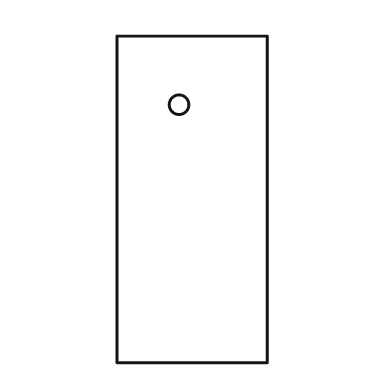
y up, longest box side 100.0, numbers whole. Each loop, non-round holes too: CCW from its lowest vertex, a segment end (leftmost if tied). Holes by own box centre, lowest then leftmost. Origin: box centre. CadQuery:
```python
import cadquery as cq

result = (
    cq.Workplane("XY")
    .moveTo(-23.0, -50.0)
    .lineTo(23.0, -50.0)
    .lineTo(23.0, 50.0)
    .lineTo(-23.0, 50.0)
    .close()
    .moveTo(-4.0, 29.0)
    .circle(3.0)
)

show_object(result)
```